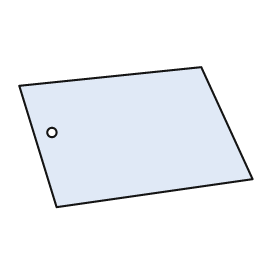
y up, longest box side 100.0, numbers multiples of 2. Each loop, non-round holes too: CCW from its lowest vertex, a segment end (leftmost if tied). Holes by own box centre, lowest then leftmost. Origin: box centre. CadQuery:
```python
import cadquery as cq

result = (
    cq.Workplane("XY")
    .moveTo(-34.0, -30.0)
    .lineTo(50.0, -18.0)
    .lineTo(28.0, 30.0)
    .lineTo(-50.0, 22.0)
    .close()
    .moveTo(-36.0, 2.0)
    .circle(2.0)
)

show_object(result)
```